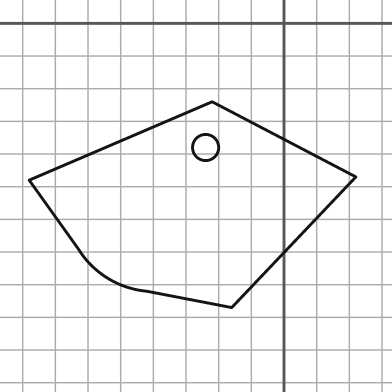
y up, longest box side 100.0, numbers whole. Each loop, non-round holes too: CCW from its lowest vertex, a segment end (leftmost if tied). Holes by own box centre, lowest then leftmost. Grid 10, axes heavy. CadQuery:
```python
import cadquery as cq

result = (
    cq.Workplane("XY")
    .moveTo(-16.0, -87.0)
    .lineTo(22.0, -47.0)
    .lineTo(-22.0, -24.0)
    .lineTo(-78.0, -48.0)
    .lineTo(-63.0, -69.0)
    .threePointArc((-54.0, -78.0), (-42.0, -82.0))
    .close()
    .moveTo(-24.0, -38.0)
    .circle(4.0)
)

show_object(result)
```